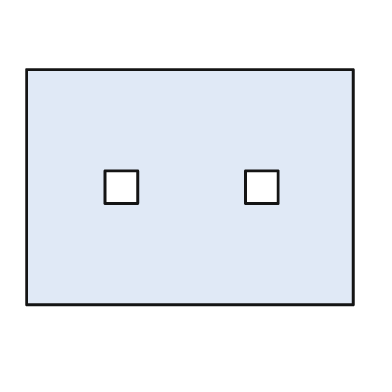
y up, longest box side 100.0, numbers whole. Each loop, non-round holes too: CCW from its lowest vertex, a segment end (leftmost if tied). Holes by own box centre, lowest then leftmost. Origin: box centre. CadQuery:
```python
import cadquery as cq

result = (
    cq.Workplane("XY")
    .moveTo(-50.0, -36.0)
    .lineTo(50.0, -36.0)
    .lineTo(50.0, 36.0)
    .lineTo(-50.0, 36.0)
    .close()
    .moveTo(-26.0, -5.0)
    .lineTo(-16.0, -5.0)
    .lineTo(-16.0, 5.0)
    .lineTo(-26.0, 5.0)
    .close()
    .moveTo(17.0, -5.0)
    .lineTo(27.0, -5.0)
    .lineTo(27.0, 5.0)
    .lineTo(17.0, 5.0)
    .close()
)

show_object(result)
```